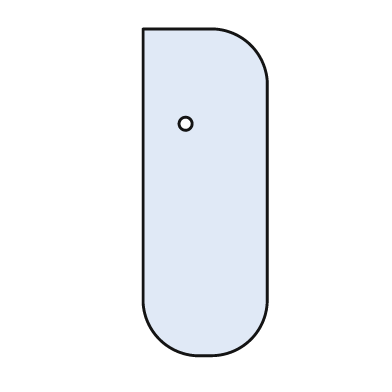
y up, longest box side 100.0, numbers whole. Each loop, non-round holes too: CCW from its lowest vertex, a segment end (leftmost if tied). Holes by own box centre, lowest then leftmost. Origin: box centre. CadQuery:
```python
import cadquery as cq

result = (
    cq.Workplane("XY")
    .moveTo(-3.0, -50.0)
    .lineTo(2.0, -50.0)
    .threePointArc((14.0, -45.0), (19.0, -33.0))
    .lineTo(19.0, 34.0)
    .threePointArc((14.0, 45.0), (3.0, 50.0))
    .lineTo(-19.0, 50.0)
    .lineTo(-19.0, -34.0)
    .threePointArc((-14.0, -45.0), (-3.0, -50.0))
    .close()
    .moveTo(-6.0, 21.0)
    .circle(2.0)
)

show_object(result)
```